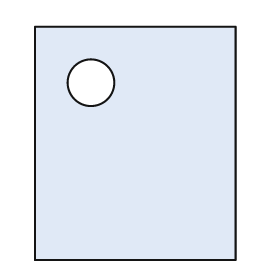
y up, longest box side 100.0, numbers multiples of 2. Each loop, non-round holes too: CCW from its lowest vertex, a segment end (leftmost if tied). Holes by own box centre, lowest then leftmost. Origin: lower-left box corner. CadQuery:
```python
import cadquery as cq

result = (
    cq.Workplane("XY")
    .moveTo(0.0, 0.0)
    .lineTo(86.0, 0.0)
    .lineTo(86.0, 100.0)
    .lineTo(0.0, 100.0)
    .close()
    .moveTo(24.0, 76.0)
    .circle(10.0)
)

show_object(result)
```